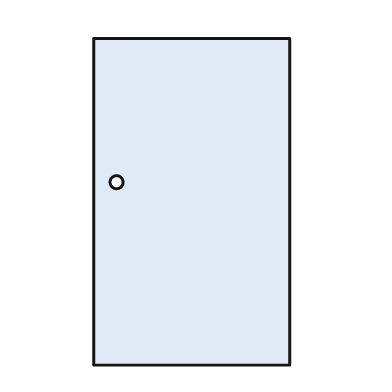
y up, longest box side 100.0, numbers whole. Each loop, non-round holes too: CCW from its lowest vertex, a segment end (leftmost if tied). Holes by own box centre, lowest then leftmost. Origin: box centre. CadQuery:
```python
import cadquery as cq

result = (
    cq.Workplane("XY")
    .moveTo(-30.0, -50.0)
    .lineTo(30.0, -50.0)
    .lineTo(30.0, 50.0)
    .lineTo(-30.0, 50.0)
    .close()
    .moveTo(-23.0, 6.0)
    .circle(2.0)
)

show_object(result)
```